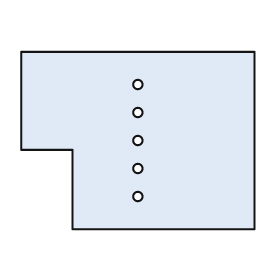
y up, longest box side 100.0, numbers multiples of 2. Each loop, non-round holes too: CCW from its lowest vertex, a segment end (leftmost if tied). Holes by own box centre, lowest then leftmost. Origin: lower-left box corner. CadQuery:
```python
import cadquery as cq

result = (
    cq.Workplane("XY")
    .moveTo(22.0, 0.0)
    .lineTo(100.0, 0.0)
    .lineTo(100.0, 76.0)
    .lineTo(0.0, 76.0)
    .lineTo(0.0, 34.0)
    .lineTo(22.0, 34.0)
    .close()
    .moveTo(50.0, 14.0)
    .circle(2.0)
    .moveTo(50.0, 26.0)
    .circle(2.0)
    .moveTo(50.0, 38.0)
    .circle(2.0)
    .moveTo(50.0, 50.0)
    .circle(2.0)
    .moveTo(50.0, 62.0)
    .circle(2.0)
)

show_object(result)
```